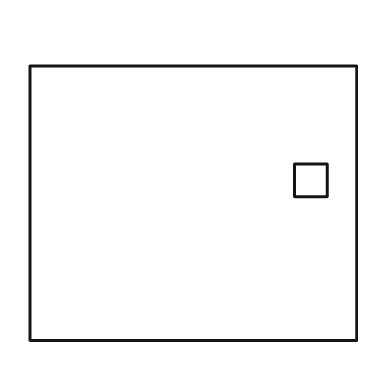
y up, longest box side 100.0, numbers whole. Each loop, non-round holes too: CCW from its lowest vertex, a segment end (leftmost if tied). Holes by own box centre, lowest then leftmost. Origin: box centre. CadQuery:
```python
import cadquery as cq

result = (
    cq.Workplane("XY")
    .moveTo(-50.0, -42.0)
    .lineTo(50.0, -42.0)
    .lineTo(50.0, 42.0)
    .lineTo(-50.0, 42.0)
    .close()
    .moveTo(31.0, 2.0)
    .lineTo(41.0, 2.0)
    .lineTo(41.0, 12.0)
    .lineTo(31.0, 12.0)
    .close()
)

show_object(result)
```